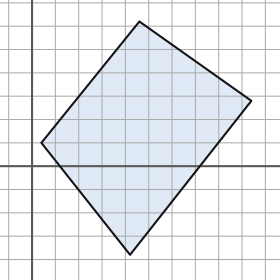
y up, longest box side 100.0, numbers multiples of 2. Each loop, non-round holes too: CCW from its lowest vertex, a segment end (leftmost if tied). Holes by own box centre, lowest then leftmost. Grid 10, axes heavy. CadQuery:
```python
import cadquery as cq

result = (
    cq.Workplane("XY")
    .moveTo(42.0, -38.0)
    .lineTo(94.0, 28.0)
    .lineTo(46.0, 62.0)
    .lineTo(4.0, 10.0)
    .close()
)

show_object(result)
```